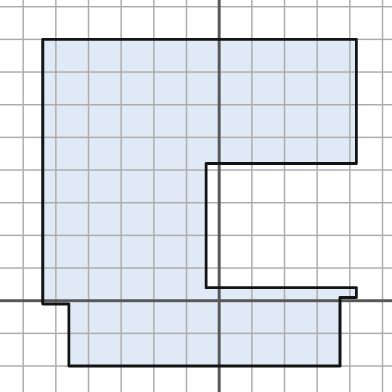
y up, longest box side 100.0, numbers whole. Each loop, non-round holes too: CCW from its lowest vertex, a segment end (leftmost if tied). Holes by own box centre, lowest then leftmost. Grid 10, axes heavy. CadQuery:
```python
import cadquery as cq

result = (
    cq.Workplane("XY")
    .moveTo(-46.0, -20.0)
    .lineTo(37.0, -20.0)
    .lineTo(37.0, 1.0)
    .lineTo(42.0, 1.0)
    .lineTo(42.0, 4.0)
    .lineTo(-4.0, 4.0)
    .lineTo(-4.0, 42.0)
    .lineTo(42.0, 42.0)
    .lineTo(42.0, 80.0)
    .lineTo(-54.0, 80.0)
    .lineTo(-54.0, -1.0)
    .lineTo(-46.0, -1.0)
    .close()
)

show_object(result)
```